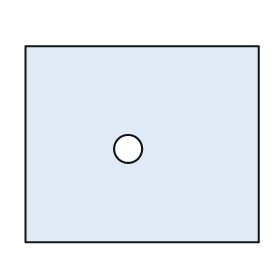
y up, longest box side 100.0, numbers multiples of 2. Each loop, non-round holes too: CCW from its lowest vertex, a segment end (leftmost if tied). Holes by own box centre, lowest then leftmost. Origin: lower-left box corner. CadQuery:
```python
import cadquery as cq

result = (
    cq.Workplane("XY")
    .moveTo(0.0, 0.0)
    .lineTo(100.0, 0.0)
    .lineTo(100.0, 84.0)
    .lineTo(0.0, 84.0)
    .close()
    .moveTo(44.0, 40.0)
    .circle(6.0)
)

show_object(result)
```